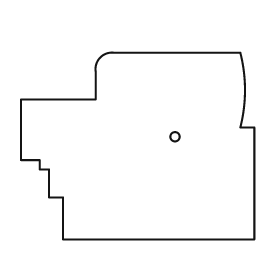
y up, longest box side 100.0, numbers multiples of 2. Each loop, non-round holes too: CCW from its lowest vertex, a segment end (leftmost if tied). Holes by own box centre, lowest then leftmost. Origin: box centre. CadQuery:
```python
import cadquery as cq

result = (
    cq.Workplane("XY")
    .moveTo(-32.0, -40.0)
    .lineTo(50.0, -40.0)
    .lineTo(50.0, 8.0)
    .lineTo(44.0, 8.0)
    .threePointArc((46.0, 24.0), (44.0, 40.0))
    .lineTo(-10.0, 40.0)
    .threePointArc((-16.0, 38.0), (-18.0, 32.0))
    .lineTo(-18.0, 20.0)
    .lineTo(-50.0, 20.0)
    .lineTo(-50.0, -6.0)
    .lineTo(-42.0, -6.0)
    .lineTo(-42.0, -10.0)
    .lineTo(-38.0, -10.0)
    .lineTo(-38.0, -22.0)
    .lineTo(-32.0, -22.0)
    .close()
    .moveTo(16.0, 4.0)
    .circle(2.0)
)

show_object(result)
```